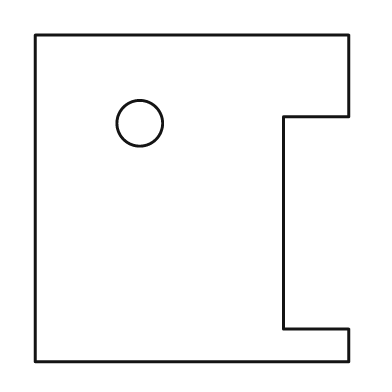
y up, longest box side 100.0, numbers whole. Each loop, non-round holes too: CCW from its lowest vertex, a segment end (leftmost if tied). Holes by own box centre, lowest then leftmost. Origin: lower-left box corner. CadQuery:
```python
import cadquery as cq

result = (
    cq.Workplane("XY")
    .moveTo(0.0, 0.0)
    .lineTo(96.0, 0.0)
    .lineTo(96.0, 10.0)
    .lineTo(76.0, 10.0)
    .lineTo(76.0, 75.0)
    .lineTo(96.0, 75.0)
    .lineTo(96.0, 100.0)
    .lineTo(0.0, 100.0)
    .close()
    .moveTo(32.0, 73.0)
    .circle(7.0)
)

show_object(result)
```